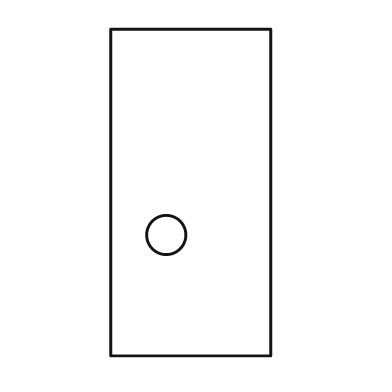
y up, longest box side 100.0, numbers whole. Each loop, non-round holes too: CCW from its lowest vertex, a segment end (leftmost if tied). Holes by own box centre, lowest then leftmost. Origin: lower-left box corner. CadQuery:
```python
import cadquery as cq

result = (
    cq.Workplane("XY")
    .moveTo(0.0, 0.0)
    .lineTo(49.0, 0.0)
    .lineTo(49.0, 100.0)
    .lineTo(0.0, 100.0)
    .close()
    .moveTo(17.0, 37.0)
    .circle(6.0)
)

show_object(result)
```